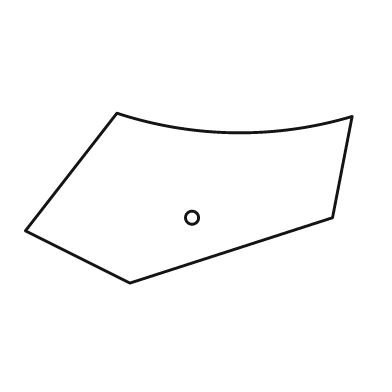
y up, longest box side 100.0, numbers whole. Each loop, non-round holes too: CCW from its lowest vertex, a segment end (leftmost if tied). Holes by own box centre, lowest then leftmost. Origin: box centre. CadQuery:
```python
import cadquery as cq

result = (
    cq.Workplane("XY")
    .moveTo(-18.0, -26.0)
    .lineTo(44.0, -6.0)
    .lineTo(50.0, 25.0)
    .threePointArc((14.0, 20.0), (-22.0, 26.0))
    .lineTo(-50.0, -10.0)
    .close()
    .moveTo(1.0, -6.0)
    .circle(2.0)
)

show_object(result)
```